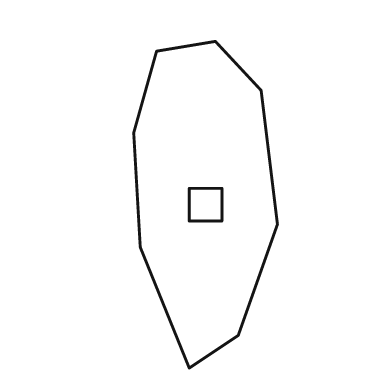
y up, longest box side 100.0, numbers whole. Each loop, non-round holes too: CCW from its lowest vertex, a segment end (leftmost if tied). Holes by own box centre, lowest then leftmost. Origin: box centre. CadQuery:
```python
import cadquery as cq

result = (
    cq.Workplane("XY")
    .moveTo(-5.0, -50.0)
    .lineTo(10.0, -40.0)
    .lineTo(22.0, -6.0)
    .lineTo(17.0, 35.0)
    .lineTo(3.0, 50.0)
    .lineTo(-15.0, 47.0)
    .lineTo(-22.0, 22.0)
    .lineTo(-20.0, -13.0)
    .close()
    .moveTo(-5.0, -5.0)
    .lineTo(5.0, -5.0)
    .lineTo(5.0, 5.0)
    .lineTo(-5.0, 5.0)
    .close()
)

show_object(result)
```